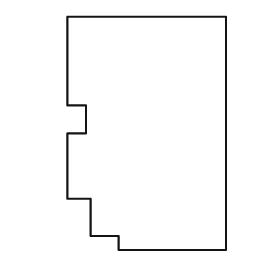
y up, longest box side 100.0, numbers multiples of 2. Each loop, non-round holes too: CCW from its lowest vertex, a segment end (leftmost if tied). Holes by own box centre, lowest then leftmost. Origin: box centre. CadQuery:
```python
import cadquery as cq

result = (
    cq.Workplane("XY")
    .moveTo(-12.0, -50.0)
    .lineTo(34.0, -50.0)
    .lineTo(34.0, 50.0)
    .lineTo(-34.0, 50.0)
    .lineTo(-34.0, 12.0)
    .lineTo(-26.0, 12.0)
    .lineTo(-26.0, 0.0)
    .lineTo(-34.0, 0.0)
    .lineTo(-34.0, -28.0)
    .lineTo(-24.0, -28.0)
    .lineTo(-24.0, -44.0)
    .lineTo(-12.0, -44.0)
    .close()
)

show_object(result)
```